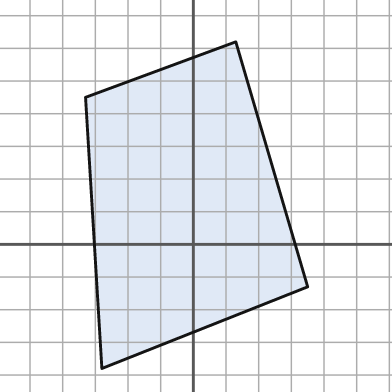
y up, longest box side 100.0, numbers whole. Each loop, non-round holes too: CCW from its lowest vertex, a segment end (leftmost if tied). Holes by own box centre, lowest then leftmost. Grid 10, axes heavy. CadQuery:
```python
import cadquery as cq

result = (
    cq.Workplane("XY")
    .moveTo(-28.0, -38.0)
    .lineTo(35.0, -13.0)
    .lineTo(13.0, 62.0)
    .lineTo(-33.0, 45.0)
    .close()
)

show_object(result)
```